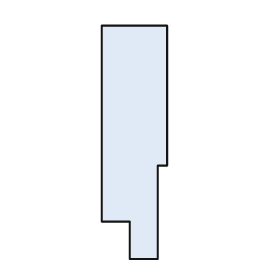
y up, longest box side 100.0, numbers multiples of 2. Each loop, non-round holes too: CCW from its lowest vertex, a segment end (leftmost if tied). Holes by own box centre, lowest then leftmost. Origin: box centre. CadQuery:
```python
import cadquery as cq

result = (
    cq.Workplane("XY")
    .moveTo(-2.0, -50.0)
    .lineTo(10.0, -50.0)
    .lineTo(10.0, -10.0)
    .lineTo(14.0, -10.0)
    .lineTo(14.0, 50.0)
    .lineTo(-14.0, 50.0)
    .lineTo(-14.0, -34.0)
    .lineTo(-2.0, -34.0)
    .close()
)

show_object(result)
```